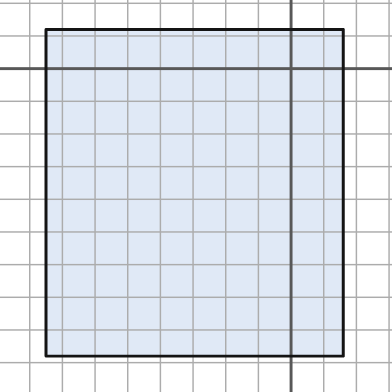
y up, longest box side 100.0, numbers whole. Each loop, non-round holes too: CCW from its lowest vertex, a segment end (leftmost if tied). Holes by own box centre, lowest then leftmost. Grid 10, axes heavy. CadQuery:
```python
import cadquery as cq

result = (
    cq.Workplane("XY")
    .moveTo(-75.0, -88.0)
    .lineTo(16.0, -88.0)
    .lineTo(16.0, 12.0)
    .lineTo(-75.0, 12.0)
    .close()
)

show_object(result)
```